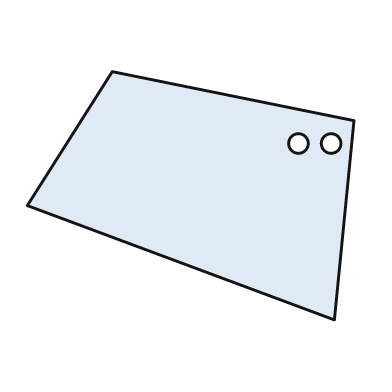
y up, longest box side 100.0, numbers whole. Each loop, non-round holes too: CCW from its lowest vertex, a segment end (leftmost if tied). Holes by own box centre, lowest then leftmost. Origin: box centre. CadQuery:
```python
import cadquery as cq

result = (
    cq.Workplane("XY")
    .moveTo(44.0, -38.0)
    .lineTo(50.0, 23.0)
    .lineTo(-24.0, 38.0)
    .lineTo(-50.0, -3.0)
    .close()
    .moveTo(33.0, 16.0)
    .circle(3.0)
    .moveTo(43.0, 16.0)
    .circle(3.0)
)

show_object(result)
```